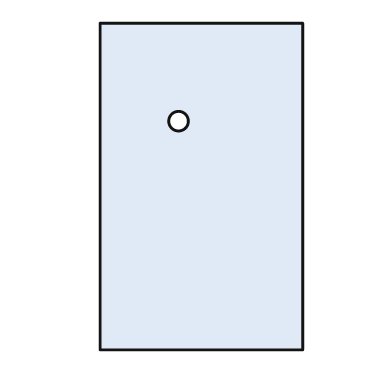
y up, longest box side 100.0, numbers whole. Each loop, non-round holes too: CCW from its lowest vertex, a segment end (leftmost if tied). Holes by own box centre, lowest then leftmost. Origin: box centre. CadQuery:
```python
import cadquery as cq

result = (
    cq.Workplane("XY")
    .moveTo(-31.0, -50.0)
    .lineTo(31.0, -50.0)
    .lineTo(31.0, 50.0)
    .lineTo(-31.0, 50.0)
    .close()
    .moveTo(-7.0, 20.0)
    .circle(3.0)
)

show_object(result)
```